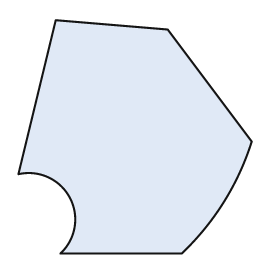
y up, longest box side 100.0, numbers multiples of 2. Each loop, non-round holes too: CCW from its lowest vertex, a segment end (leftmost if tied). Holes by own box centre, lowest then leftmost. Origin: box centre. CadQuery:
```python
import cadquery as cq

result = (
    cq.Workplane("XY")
    .moveTo(-32.0, -50.0)
    .lineTo(20.0, -50.0)
    .threePointArc((38.0, -28.0), (50.0, -2.0))
    .lineTo(14.0, 46.0)
    .lineTo(-34.0, 50.0)
    .lineTo(-50.0, -16.0)
    .threePointArc((-28.0, -26.0), (-32.0, -50.0))
    .close()
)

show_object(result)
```